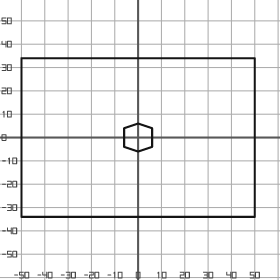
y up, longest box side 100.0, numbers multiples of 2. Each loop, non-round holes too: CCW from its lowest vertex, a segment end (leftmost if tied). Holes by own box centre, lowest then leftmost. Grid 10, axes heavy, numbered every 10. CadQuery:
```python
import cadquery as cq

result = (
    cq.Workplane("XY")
    .moveTo(-50.0, -34.0)
    .lineTo(50.0, -34.0)
    .lineTo(50.0, 34.0)
    .lineTo(-50.0, 34.0)
    .close()
    .moveTo(0.0, -6.0)
    .lineTo(6.0, -4.0)
    .lineTo(6.0, 4.0)
    .lineTo(0.0, 6.0)
    .lineTo(-6.0, 4.0)
    .lineTo(-6.0, -4.0)
    .close()
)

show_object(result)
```